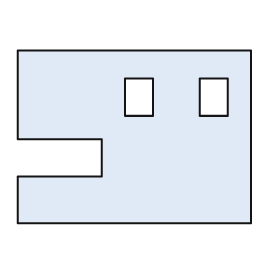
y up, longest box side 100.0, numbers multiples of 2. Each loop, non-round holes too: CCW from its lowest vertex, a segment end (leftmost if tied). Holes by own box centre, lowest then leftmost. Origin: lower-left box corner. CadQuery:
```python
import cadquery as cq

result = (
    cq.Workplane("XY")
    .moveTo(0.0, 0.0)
    .lineTo(100.0, 0.0)
    .lineTo(100.0, 74.0)
    .lineTo(0.0, 74.0)
    .lineTo(0.0, 36.0)
    .lineTo(36.0, 36.0)
    .lineTo(36.0, 20.0)
    .lineTo(0.0, 20.0)
    .close()
    .moveTo(46.0, 46.0)
    .lineTo(58.0, 46.0)
    .lineTo(58.0, 62.0)
    .lineTo(46.0, 62.0)
    .close()
    .moveTo(78.0, 46.0)
    .lineTo(90.0, 46.0)
    .lineTo(90.0, 62.0)
    .lineTo(78.0, 62.0)
    .close()
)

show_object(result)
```